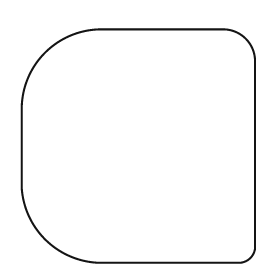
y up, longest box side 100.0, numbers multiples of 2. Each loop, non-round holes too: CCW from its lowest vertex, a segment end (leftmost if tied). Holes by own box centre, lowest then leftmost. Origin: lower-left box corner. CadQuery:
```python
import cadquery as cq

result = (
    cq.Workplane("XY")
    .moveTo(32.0, 0.0)
    .lineTo(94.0, 0.0)
    .threePointArc((98.0, 2.0), (100.0, 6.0))
    .lineTo(100.0, 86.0)
    .threePointArc((96.0, 96.0), (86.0, 100.0))
    .lineTo(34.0, 100.0)
    .threePointArc((10.0, 90.0), (0.0, 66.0))
    .lineTo(0.0, 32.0)
    .threePointArc((10.0, 10.0), (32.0, 0.0))
    .close()
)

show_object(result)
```